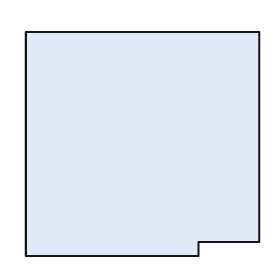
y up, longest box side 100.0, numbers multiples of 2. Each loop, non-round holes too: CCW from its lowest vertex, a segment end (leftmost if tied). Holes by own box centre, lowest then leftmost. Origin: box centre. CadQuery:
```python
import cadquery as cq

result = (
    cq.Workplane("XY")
    .moveTo(-50.0, -48.0)
    .lineTo(24.0, -48.0)
    .lineTo(24.0, -42.0)
    .lineTo(50.0, -42.0)
    .lineTo(50.0, 48.0)
    .lineTo(-50.0, 48.0)
    .close()
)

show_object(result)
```